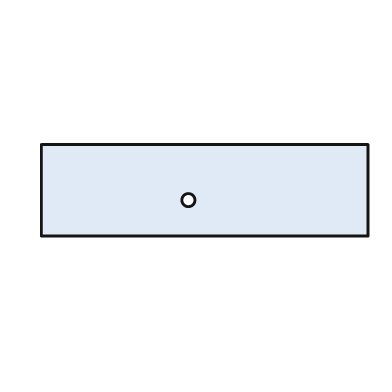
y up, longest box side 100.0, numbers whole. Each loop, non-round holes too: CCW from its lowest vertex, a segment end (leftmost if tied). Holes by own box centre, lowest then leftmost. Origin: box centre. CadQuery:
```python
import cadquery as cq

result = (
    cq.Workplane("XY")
    .moveTo(-50.0, -14.0)
    .lineTo(50.0, -14.0)
    .lineTo(50.0, 14.0)
    .lineTo(-50.0, 14.0)
    .close()
    .moveTo(-5.0, -3.0)
    .circle(2.0)
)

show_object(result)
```